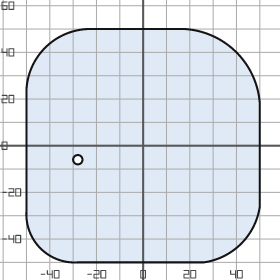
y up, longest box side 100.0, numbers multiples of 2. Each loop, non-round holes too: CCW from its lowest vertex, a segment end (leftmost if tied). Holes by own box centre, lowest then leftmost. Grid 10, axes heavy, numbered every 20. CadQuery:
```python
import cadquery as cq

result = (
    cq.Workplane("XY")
    .moveTo(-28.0, -50.0)
    .lineTo(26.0, -50.0)
    .threePointArc((42.0, -42.0), (50.0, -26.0))
    .lineTo(50.0, 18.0)
    .threePointArc((40.0, 40.0), (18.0, 50.0))
    .lineTo(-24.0, 50.0)
    .threePointArc((-42.0, 42.0), (-50.0, 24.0))
    .lineTo(-50.0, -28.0)
    .threePointArc((-44.0, -44.0), (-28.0, -50.0))
    .close()
    .moveTo(-28.0, -6.0)
    .circle(2.0)
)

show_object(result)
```